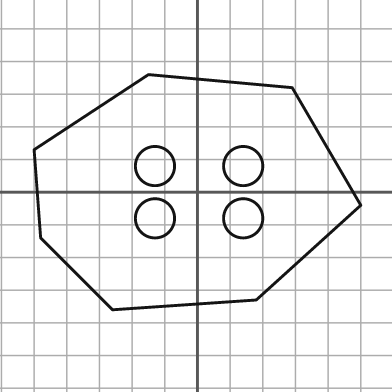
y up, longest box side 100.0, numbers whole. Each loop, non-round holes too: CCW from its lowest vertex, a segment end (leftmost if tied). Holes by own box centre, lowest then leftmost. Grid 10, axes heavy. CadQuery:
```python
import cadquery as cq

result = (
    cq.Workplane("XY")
    .moveTo(-26.0, -36.0)
    .lineTo(18.0, -33.0)
    .lineTo(50.0, -4.0)
    .lineTo(29.0, 32.0)
    .lineTo(-15.0, 36.0)
    .lineTo(-50.0, 13.0)
    .lineTo(-48.0, -14.0)
    .close()
    .moveTo(-13.0, -8.0)
    .circle(6.0)
    .moveTo(14.0, -8.0)
    .circle(6.0)
    .moveTo(-13.0, 8.0)
    .circle(6.0)
    .moveTo(14.0, 8.0)
    .circle(6.0)
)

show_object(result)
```